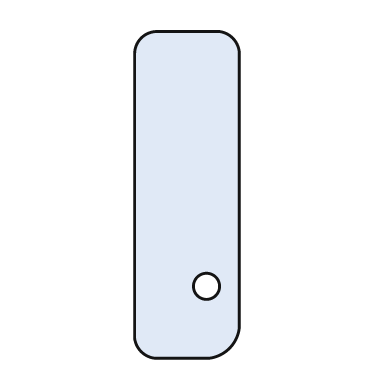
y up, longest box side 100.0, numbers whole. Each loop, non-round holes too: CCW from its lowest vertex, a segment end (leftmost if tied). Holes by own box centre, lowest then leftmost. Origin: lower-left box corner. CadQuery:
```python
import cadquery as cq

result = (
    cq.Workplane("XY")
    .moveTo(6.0, 0.0)
    .lineTo(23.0, 0.0)
    .threePointArc((29.0, 3.0), (32.0, 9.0))
    .lineTo(32.0, 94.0)
    .threePointArc((30.0, 98.0), (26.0, 100.0))
    .lineTo(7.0, 100.0)
    .threePointArc((2.0, 98.0), (0.0, 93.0))
    .lineTo(0.0, 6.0)
    .threePointArc((2.0, 2.0), (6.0, 0.0))
    .close()
    .moveTo(22.0, 22.0)
    .circle(4.0)
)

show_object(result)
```